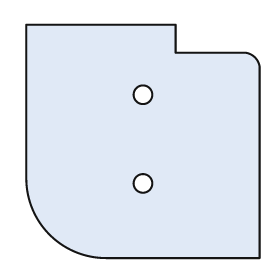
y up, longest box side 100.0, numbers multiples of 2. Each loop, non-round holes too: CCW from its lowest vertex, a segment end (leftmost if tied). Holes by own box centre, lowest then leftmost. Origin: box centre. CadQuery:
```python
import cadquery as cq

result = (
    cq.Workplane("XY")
    .moveTo(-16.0, -50.0)
    .lineTo(50.0, -50.0)
    .lineTo(50.0, 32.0)
    .threePointArc((48.0, 36.0), (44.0, 38.0))
    .lineTo(14.0, 38.0)
    .lineTo(14.0, 50.0)
    .lineTo(-50.0, 50.0)
    .lineTo(-50.0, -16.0)
    .threePointArc((-40.0, -40.0), (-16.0, -50.0))
    .close()
    .moveTo(0.0, -18.0)
    .circle(4.0)
    .moveTo(0.0, 20.0)
    .circle(4.0)
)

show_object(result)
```